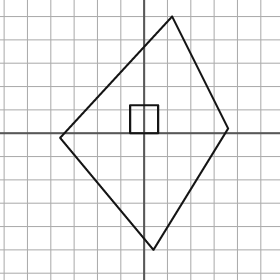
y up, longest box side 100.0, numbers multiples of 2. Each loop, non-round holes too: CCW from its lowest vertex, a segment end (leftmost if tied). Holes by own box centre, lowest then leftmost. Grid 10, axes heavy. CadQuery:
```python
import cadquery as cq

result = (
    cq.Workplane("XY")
    .moveTo(4.0, -50.0)
    .lineTo(36.0, 2.0)
    .lineTo(12.0, 50.0)
    .lineTo(-36.0, -2.0)
    .close()
    .moveTo(-6.0, 0.0)
    .lineTo(6.0, 0.0)
    .lineTo(6.0, 12.0)
    .lineTo(-6.0, 12.0)
    .close()
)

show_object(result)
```